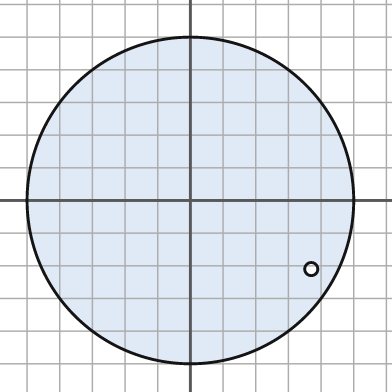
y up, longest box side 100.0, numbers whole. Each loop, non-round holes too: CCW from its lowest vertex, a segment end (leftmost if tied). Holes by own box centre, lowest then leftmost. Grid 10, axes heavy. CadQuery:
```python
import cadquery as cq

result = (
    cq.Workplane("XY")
    .moveTo(0.0, 0.0)
    .circle(50.0)
    .moveTo(37.0, -21.0)
    .circle(2.0)
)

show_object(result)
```